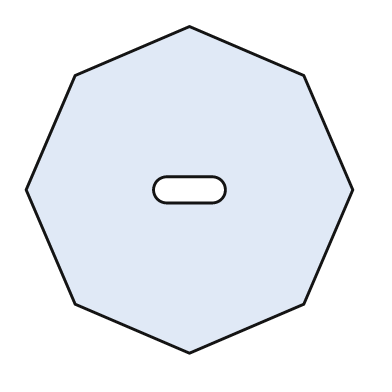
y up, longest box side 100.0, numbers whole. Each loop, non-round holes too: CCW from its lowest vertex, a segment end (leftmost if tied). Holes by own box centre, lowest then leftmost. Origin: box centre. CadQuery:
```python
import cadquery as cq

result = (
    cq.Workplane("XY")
    .moveTo(0.0, -50.0)
    .lineTo(35.0, -35.0)
    .lineTo(50.0, 0.0)
    .lineTo(35.0, 35.0)
    .lineTo(0.0, 50.0)
    .lineTo(-35.0, 35.0)
    .lineTo(-50.0, 0.0)
    .lineTo(-35.0, -35.0)
    .close()
    .moveTo(-7.0, -4.0)
    .lineTo(7.0, -4.0)
    .threePointArc((11.0, 0.0), (7.0, 4.0))
    .lineTo(-7.0, 4.0)
    .threePointArc((-11.0, 0.0), (-7.0, -4.0))
    .close()
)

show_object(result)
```